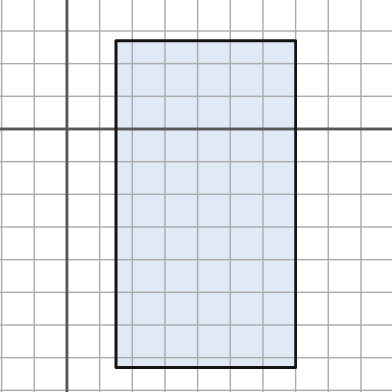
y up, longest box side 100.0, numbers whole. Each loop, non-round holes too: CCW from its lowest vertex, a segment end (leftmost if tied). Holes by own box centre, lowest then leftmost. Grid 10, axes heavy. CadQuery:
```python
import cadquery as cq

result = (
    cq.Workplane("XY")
    .moveTo(15.0, -73.0)
    .lineTo(70.0, -73.0)
    .lineTo(70.0, 27.0)
    .lineTo(15.0, 27.0)
    .close()
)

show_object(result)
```